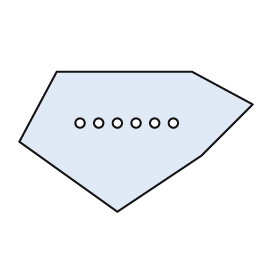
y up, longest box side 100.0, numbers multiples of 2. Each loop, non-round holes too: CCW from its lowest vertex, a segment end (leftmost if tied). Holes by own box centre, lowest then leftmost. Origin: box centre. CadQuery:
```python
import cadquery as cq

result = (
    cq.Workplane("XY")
    .moveTo(-8.0, -30.0)
    .lineTo(28.0, -6.0)
    .lineTo(50.0, 16.0)
    .lineTo(24.0, 30.0)
    .lineTo(-34.0, 30.0)
    .lineTo(-50.0, 0.0)
    .close()
    .moveTo(-24.0, 8.0)
    .circle(2.0)
    .moveTo(-16.0, 8.0)
    .circle(2.0)
    .moveTo(-8.0, 8.0)
    .circle(2.0)
    .moveTo(0.0, 8.0)
    .circle(2.0)
    .moveTo(8.0, 8.0)
    .circle(2.0)
    .moveTo(16.0, 8.0)
    .circle(2.0)
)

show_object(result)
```